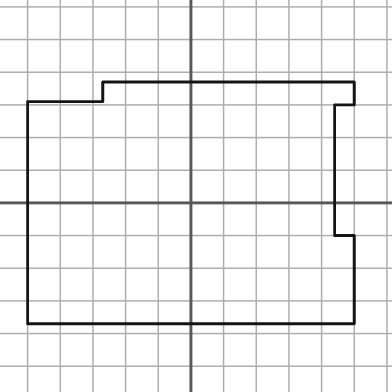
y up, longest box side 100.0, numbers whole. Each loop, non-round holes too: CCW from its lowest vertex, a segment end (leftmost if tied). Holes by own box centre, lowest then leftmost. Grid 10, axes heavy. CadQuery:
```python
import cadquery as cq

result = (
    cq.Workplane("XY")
    .moveTo(-50.0, -37.0)
    .lineTo(50.0, -37.0)
    .lineTo(50.0, -10.0)
    .lineTo(44.0, -10.0)
    .lineTo(44.0, 30.0)
    .lineTo(50.0, 30.0)
    .lineTo(50.0, 37.0)
    .lineTo(-27.0, 37.0)
    .lineTo(-27.0, 31.0)
    .lineTo(-50.0, 31.0)
    .close()
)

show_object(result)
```